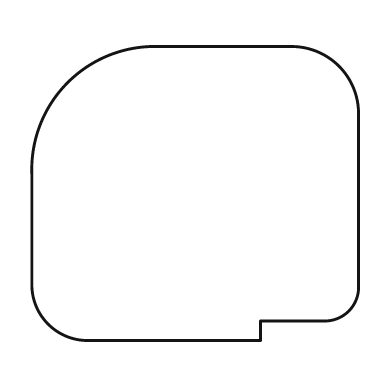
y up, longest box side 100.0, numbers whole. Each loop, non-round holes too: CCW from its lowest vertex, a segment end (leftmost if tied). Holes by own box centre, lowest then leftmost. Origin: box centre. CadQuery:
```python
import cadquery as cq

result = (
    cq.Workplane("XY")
    .moveTo(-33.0, -45.0)
    .lineTo(20.0, -45.0)
    .lineTo(20.0, -39.0)
    .lineTo(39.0, -39.0)
    .threePointArc((47.0, -36.0), (50.0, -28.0))
    .lineTo(50.0, 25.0)
    .threePointArc((44.0, 39.0), (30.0, 45.0))
    .lineTo(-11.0, 45.0)
    .threePointArc((-39.0, 34.0), (-50.0, 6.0))
    .lineTo(-50.0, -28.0)
    .threePointArc((-45.0, -40.0), (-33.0, -45.0))
    .close()
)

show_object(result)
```